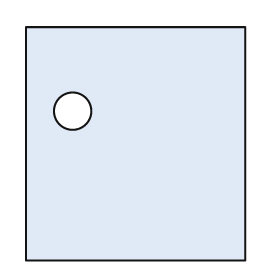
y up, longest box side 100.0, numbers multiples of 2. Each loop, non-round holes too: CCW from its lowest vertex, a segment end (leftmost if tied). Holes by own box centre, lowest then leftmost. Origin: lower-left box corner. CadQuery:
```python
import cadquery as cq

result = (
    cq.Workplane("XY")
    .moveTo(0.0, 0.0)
    .lineTo(94.0, 0.0)
    .lineTo(94.0, 100.0)
    .lineTo(0.0, 100.0)
    .close()
    .moveTo(20.0, 64.0)
    .circle(8.0)
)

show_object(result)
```